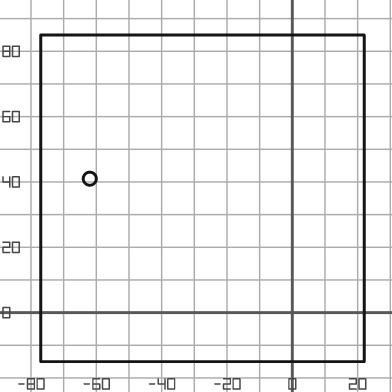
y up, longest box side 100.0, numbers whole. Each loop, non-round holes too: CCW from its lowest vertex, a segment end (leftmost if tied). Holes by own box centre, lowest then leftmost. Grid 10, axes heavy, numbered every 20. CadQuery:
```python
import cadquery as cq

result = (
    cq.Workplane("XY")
    .moveTo(-77.0, -15.0)
    .lineTo(22.0, -15.0)
    .lineTo(22.0, 85.0)
    .lineTo(-77.0, 85.0)
    .close()
    .moveTo(-62.0, 41.0)
    .circle(2.0)
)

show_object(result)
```